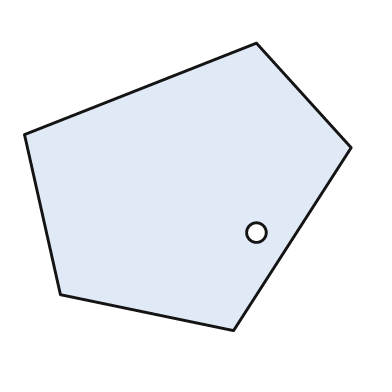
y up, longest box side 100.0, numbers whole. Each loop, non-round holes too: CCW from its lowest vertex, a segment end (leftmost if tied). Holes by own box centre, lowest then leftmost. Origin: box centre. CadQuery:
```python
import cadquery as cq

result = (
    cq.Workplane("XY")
    .moveTo(14.0, -44.0)
    .lineTo(50.0, 12.0)
    .lineTo(21.0, 44.0)
    .lineTo(-50.0, 16.0)
    .lineTo(-39.0, -33.0)
    .close()
    .moveTo(21.0, -14.0)
    .circle(3.0)
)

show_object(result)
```